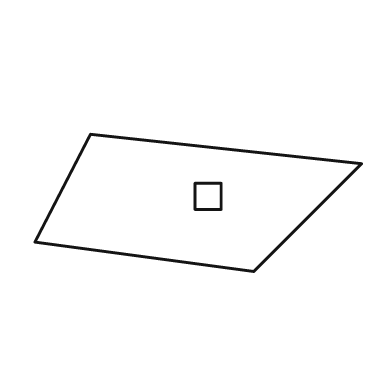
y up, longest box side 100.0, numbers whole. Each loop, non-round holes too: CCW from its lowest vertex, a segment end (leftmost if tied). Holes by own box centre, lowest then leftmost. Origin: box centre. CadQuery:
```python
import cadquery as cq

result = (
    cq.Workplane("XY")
    .moveTo(17.0, -21.0)
    .lineTo(50.0, 12.0)
    .lineTo(-33.0, 21.0)
    .lineTo(-50.0, -12.0)
    .close()
    .moveTo(-1.0, -2.0)
    .lineTo(7.0, -2.0)
    .lineTo(7.0, 6.0)
    .lineTo(-1.0, 6.0)
    .close()
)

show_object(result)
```